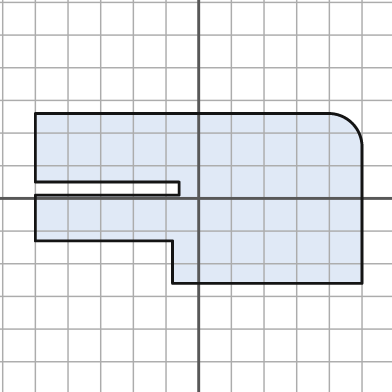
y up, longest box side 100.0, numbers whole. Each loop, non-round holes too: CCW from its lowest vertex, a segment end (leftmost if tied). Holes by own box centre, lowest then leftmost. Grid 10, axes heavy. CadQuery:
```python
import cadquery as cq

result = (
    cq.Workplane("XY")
    .moveTo(-8.0, -26.0)
    .lineTo(50.0, -26.0)
    .lineTo(50.0, 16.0)
    .threePointArc((47.0, 23.0), (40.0, 26.0))
    .lineTo(-50.0, 26.0)
    .lineTo(-50.0, 5.0)
    .lineTo(-6.0, 5.0)
    .lineTo(-6.0, 1.0)
    .lineTo(-50.0, 1.0)
    .lineTo(-50.0, -13.0)
    .lineTo(-8.0, -13.0)
    .close()
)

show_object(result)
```